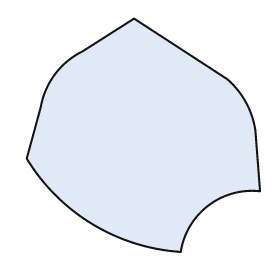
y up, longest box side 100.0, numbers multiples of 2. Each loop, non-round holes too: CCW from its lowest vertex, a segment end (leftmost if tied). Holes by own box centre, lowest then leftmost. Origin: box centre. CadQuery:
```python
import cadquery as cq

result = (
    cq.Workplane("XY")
    .moveTo(16.0, -50.0)
    .threePointArc((28.0, -30.0), (50.0, -24.0))
    .lineTo(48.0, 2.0)
    .threePointArc((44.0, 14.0), (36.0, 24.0))
    .lineTo(-4.0, 50.0)
    .lineTo(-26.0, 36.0)
    .threePointArc((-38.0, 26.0), (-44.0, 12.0))
    .lineTo(-50.0, -10.0)
    .threePointArc((-22.0, -38.0), (16.0, -50.0))
    .close()
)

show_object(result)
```